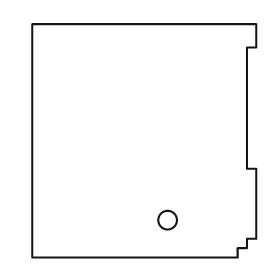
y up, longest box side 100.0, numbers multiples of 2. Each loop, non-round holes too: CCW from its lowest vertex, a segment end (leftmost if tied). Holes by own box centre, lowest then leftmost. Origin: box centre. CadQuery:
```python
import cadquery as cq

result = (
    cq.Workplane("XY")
    .moveTo(-48.0, -50.0)
    .lineTo(40.0, -50.0)
    .lineTo(40.0, -46.0)
    .lineTo(44.0, -46.0)
    .lineTo(44.0, -42.0)
    .lineTo(48.0, -42.0)
    .lineTo(48.0, -12.0)
    .lineTo(44.0, -12.0)
    .lineTo(44.0, 40.0)
    .lineTo(48.0, 40.0)
    .lineTo(48.0, 50.0)
    .lineTo(-48.0, 50.0)
    .close()
    .moveTo(10.0, -34.0)
    .circle(4.0)
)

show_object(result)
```